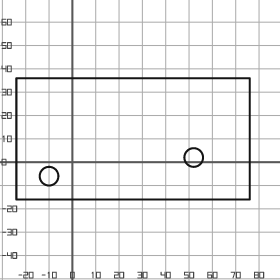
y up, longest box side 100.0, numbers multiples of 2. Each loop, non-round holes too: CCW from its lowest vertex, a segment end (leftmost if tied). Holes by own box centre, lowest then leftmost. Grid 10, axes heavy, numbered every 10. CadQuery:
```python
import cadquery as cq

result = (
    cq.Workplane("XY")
    .moveTo(-24.0, -16.0)
    .lineTo(76.0, -16.0)
    .lineTo(76.0, 36.0)
    .lineTo(-24.0, 36.0)
    .close()
    .moveTo(-10.0, -6.0)
    .circle(4.0)
    .moveTo(52.0, 2.0)
    .circle(4.0)
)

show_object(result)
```